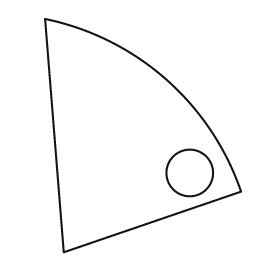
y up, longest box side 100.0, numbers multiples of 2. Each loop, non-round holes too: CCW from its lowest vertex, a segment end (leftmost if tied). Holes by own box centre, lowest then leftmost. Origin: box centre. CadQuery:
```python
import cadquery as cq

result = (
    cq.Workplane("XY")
    .moveTo(-34.0, -50.0)
    .lineTo(42.0, -24.0)
    .threePointArc((10.0, 24.0), (-42.0, 50.0))
    .close()
    .moveTo(20.0, -16.0)
    .circle(10.0)
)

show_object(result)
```